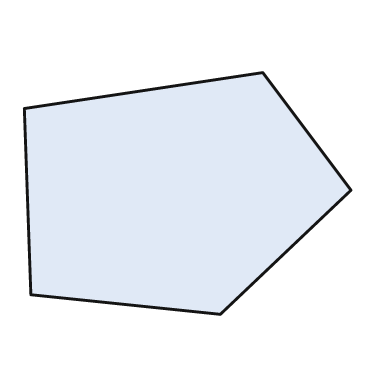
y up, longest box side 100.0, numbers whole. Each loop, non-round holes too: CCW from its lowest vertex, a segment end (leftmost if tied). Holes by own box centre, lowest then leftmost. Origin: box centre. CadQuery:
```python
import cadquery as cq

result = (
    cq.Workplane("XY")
    .moveTo(10.0, -37.0)
    .lineTo(50.0, 1.0)
    .lineTo(23.0, 37.0)
    .lineTo(-50.0, 26.0)
    .lineTo(-48.0, -31.0)
    .close()
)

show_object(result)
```